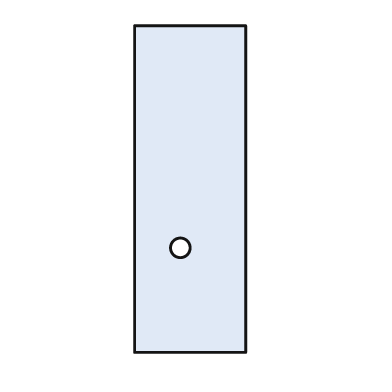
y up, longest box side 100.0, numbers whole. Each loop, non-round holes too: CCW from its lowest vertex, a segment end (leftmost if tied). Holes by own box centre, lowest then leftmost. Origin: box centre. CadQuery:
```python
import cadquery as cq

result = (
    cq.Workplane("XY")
    .moveTo(-17.0, -50.0)
    .lineTo(17.0, -50.0)
    .lineTo(17.0, 50.0)
    .lineTo(-17.0, 50.0)
    .close()
    .moveTo(-3.0, -18.0)
    .circle(3.0)
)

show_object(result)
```